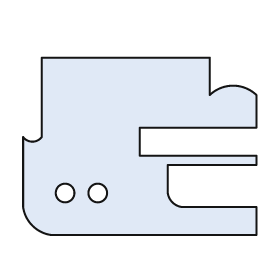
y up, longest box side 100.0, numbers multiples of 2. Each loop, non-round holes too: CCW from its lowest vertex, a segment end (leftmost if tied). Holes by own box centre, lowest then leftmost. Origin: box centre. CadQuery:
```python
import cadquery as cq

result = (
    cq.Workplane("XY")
    .moveTo(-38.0, -38.0)
    .lineTo(50.0, -38.0)
    .lineTo(50.0, -26.0)
    .lineTo(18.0, -26.0)
    .threePointArc((14.0, -24.0), (12.0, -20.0))
    .lineTo(12.0, -8.0)
    .lineTo(50.0, -8.0)
    .lineTo(50.0, -4.0)
    .lineTo(0.0, -4.0)
    .lineTo(0.0, 8.0)
    .lineTo(50.0, 8.0)
    .lineTo(50.0, 22.0)
    .threePointArc((40.0, 26.0), (30.0, 22.0))
    .lineTo(30.0, 38.0)
    .lineTo(-42.0, 38.0)
    .lineTo(-42.0, 4.0)
    .threePointArc((-46.0, 2.0), (-50.0, 4.0))
    .lineTo(-50.0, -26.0)
    .threePointArc((-46.0, -34.0), (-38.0, -38.0))
    .close()
    .moveTo(-32.0, -20.0)
    .circle(4.0)
    .moveTo(-18.0, -20.0)
    .circle(4.0)
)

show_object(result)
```